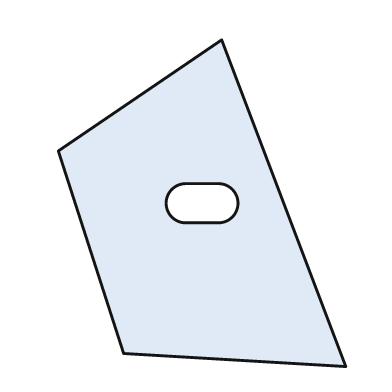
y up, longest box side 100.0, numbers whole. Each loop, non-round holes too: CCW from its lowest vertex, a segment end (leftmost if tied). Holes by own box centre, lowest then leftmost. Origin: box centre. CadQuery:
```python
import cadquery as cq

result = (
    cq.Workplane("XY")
    .moveTo(44.0, -50.0)
    .lineTo(6.0, 50.0)
    .lineTo(-44.0, 16.0)
    .lineTo(-24.0, -46.0)
    .close()
    .moveTo(-5.0, -6.0)
    .lineTo(5.0, -6.0)
    .threePointArc((11.0, 0.0), (5.0, 6.0))
    .lineTo(-5.0, 6.0)
    .threePointArc((-11.0, 0.0), (-5.0, -6.0))
    .close()
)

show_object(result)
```